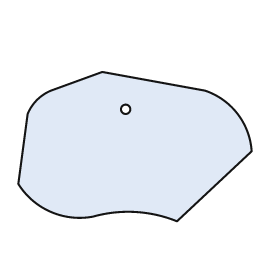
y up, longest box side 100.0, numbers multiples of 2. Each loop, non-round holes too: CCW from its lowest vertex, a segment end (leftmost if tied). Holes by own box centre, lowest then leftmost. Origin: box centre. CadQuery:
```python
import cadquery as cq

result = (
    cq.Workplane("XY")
    .moveTo(18.0, -32.0)
    .lineTo(50.0, -2.0)
    .threePointArc((44.0, 14.0), (30.0, 24.0))
    .lineTo(-14.0, 32.0)
    .lineTo(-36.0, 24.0)
    .threePointArc((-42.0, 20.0), (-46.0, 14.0))
    .lineTo(-50.0, -16.0)
    .threePointArc((-36.0, -28.0), (-18.0, -30.0))
    .threePointArc((0.0, -28.0), (18.0, -32.0))
    .close()
    .moveTo(-4.0, 16.0)
    .circle(2.0)
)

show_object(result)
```